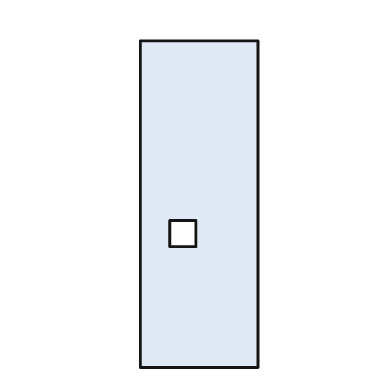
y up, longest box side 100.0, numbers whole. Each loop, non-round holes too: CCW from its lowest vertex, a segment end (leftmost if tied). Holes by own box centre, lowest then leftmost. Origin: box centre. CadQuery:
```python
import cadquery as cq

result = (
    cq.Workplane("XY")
    .moveTo(-18.0, -50.0)
    .lineTo(18.0, -50.0)
    .lineTo(18.0, 50.0)
    .lineTo(-18.0, 50.0)
    .close()
    .moveTo(-9.0, -13.0)
    .lineTo(-1.0, -13.0)
    .lineTo(-1.0, -5.0)
    .lineTo(-9.0, -5.0)
    .close()
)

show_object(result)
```